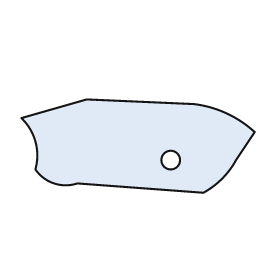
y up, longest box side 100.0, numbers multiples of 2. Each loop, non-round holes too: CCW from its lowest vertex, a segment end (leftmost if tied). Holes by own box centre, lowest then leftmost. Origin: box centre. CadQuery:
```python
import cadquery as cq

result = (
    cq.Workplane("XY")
    .moveTo(28.0, -20.0)
    .threePointArc((36.0, -14.0), (42.0, -6.0))
    .lineTo(50.0, 6.0)
    .threePointArc((38.0, 14.0), (24.0, 18.0))
    .lineTo(-22.0, 20.0)
    .lineTo(-50.0, 12.0)
    .threePointArc((-44.0, 2.0), (-44.0, -10.0))
    .threePointArc((-36.0, -16.0), (-26.0, -16.0))
    .close()
    .moveTo(14.0, -6.0)
    .circle(4.0)
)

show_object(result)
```